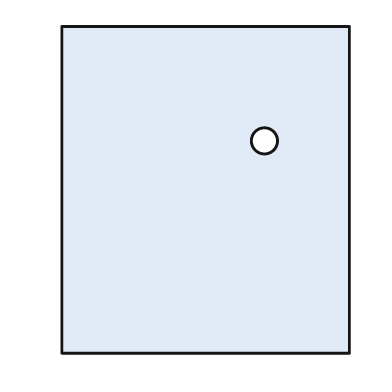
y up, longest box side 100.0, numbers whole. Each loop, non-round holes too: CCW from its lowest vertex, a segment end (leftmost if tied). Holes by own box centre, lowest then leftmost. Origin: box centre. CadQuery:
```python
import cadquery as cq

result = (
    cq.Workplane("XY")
    .moveTo(-44.0, -50.0)
    .lineTo(44.0, -50.0)
    .lineTo(44.0, 50.0)
    .lineTo(-44.0, 50.0)
    .close()
    .moveTo(18.0, 15.0)
    .circle(4.0)
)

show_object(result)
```